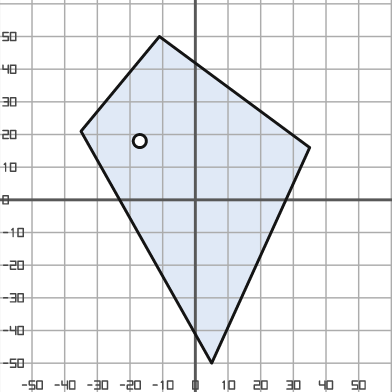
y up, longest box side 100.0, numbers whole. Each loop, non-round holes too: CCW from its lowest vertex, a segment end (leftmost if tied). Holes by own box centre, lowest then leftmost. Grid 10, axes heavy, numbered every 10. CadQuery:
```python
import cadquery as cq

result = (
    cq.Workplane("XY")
    .moveTo(5.0, -50.0)
    .lineTo(35.0, 16.0)
    .lineTo(-11.0, 50.0)
    .lineTo(-35.0, 21.0)
    .close()
    .moveTo(-17.0, 18.0)
    .circle(2.0)
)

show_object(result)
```